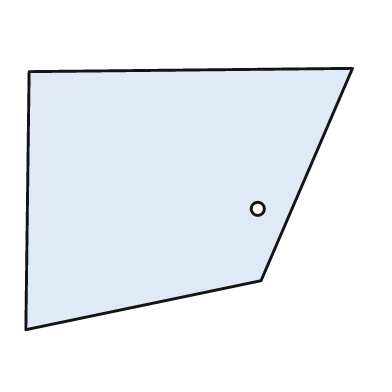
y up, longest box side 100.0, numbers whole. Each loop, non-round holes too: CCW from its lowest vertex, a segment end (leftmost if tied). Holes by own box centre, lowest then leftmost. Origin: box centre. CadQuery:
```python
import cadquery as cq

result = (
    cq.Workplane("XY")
    .moveTo(-50.0, -40.0)
    .lineTo(22.0, -25.0)
    .lineTo(50.0, 40.0)
    .lineTo(-49.0, 39.0)
    .close()
    .moveTo(21.0, -3.0)
    .circle(2.0)
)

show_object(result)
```